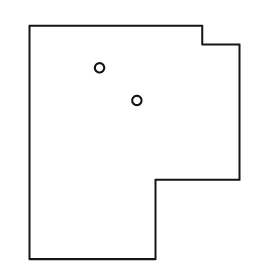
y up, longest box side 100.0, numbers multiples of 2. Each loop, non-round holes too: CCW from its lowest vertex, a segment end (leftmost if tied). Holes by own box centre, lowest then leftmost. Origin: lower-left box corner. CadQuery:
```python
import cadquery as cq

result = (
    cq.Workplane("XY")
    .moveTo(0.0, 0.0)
    .lineTo(54.0, 0.0)
    .lineTo(54.0, 34.0)
    .lineTo(90.0, 34.0)
    .lineTo(90.0, 92.0)
    .lineTo(74.0, 92.0)
    .lineTo(74.0, 100.0)
    .lineTo(0.0, 100.0)
    .close()
    .moveTo(46.0, 68.0)
    .circle(2.0)
    .moveTo(30.0, 82.0)
    .circle(2.0)
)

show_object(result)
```